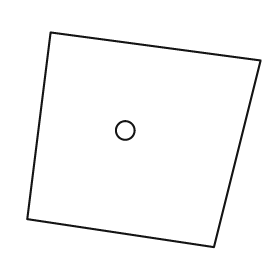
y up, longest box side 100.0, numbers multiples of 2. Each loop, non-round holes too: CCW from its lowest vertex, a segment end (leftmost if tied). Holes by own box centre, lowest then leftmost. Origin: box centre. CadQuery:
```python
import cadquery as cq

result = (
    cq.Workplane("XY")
    .moveTo(30.0, -46.0)
    .lineTo(50.0, 34.0)
    .lineTo(-40.0, 46.0)
    .lineTo(-50.0, -34.0)
    .close()
    .moveTo(-8.0, 4.0)
    .circle(4.0)
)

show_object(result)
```